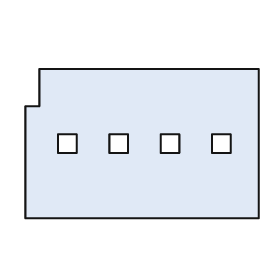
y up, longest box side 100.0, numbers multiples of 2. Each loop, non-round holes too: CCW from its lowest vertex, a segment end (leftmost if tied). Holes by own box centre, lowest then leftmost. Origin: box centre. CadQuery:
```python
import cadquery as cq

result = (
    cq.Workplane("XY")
    .moveTo(-50.0, -32.0)
    .lineTo(50.0, -32.0)
    .lineTo(50.0, 32.0)
    .lineTo(-44.0, 32.0)
    .lineTo(-44.0, 16.0)
    .lineTo(-50.0, 16.0)
    .close()
    .moveTo(-36.0, -4.0)
    .lineTo(-28.0, -4.0)
    .lineTo(-28.0, 4.0)
    .lineTo(-36.0, 4.0)
    .close()
    .moveTo(-14.0, -4.0)
    .lineTo(-6.0, -4.0)
    .lineTo(-6.0, 4.0)
    .lineTo(-14.0, 4.0)
    .close()
    .moveTo(8.0, -4.0)
    .lineTo(16.0, -4.0)
    .lineTo(16.0, 4.0)
    .lineTo(8.0, 4.0)
    .close()
    .moveTo(30.0, -4.0)
    .lineTo(38.0, -4.0)
    .lineTo(38.0, 4.0)
    .lineTo(30.0, 4.0)
    .close()
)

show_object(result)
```